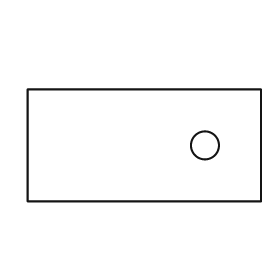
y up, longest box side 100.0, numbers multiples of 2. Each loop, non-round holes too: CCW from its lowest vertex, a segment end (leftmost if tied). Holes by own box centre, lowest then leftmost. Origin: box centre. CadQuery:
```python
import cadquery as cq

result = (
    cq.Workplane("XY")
    .moveTo(-50.0, -24.0)
    .lineTo(50.0, -24.0)
    .lineTo(50.0, 24.0)
    .lineTo(-50.0, 24.0)
    .close()
    .moveTo(26.0, 0.0)
    .circle(6.0)
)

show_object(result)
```